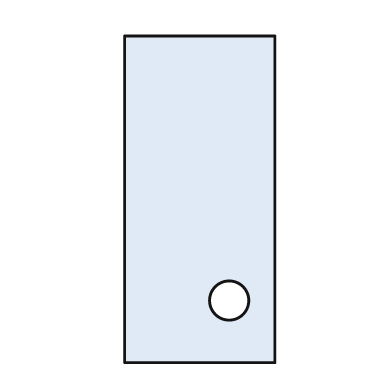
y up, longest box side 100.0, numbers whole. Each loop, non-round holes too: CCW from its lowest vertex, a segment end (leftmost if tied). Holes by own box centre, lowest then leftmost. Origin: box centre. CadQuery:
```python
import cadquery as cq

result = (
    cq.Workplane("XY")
    .moveTo(-23.0, -50.0)
    .lineTo(23.0, -50.0)
    .lineTo(23.0, 50.0)
    .lineTo(-23.0, 50.0)
    .close()
    .moveTo(9.0, -31.0)
    .circle(6.0)
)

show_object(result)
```